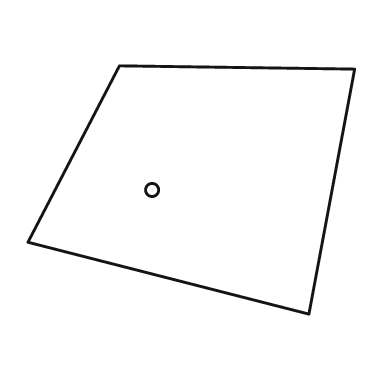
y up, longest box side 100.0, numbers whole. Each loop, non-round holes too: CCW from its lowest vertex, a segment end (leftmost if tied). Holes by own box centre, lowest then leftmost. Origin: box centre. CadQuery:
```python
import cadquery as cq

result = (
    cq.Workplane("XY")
    .moveTo(36.0, -38.0)
    .lineTo(50.0, 37.0)
    .lineTo(-22.0, 38.0)
    .lineTo(-50.0, -16.0)
    .close()
    .moveTo(-12.0, 0.0)
    .circle(2.0)
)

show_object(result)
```